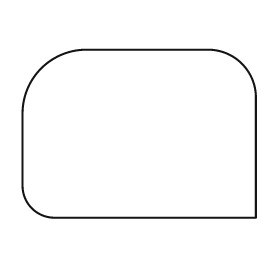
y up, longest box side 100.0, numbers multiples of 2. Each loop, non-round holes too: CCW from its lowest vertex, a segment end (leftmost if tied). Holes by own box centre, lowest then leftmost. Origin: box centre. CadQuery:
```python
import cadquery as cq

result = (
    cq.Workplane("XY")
    .moveTo(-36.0, -36.0)
    .lineTo(50.0, -36.0)
    .lineTo(50.0, 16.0)
    .threePointArc((44.0, 30.0), (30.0, 36.0))
    .lineTo(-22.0, 36.0)
    .threePointArc((-42.0, 28.0), (-50.0, 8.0))
    .lineTo(-50.0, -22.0)
    .threePointArc((-46.0, -32.0), (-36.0, -36.0))
    .close()
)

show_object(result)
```